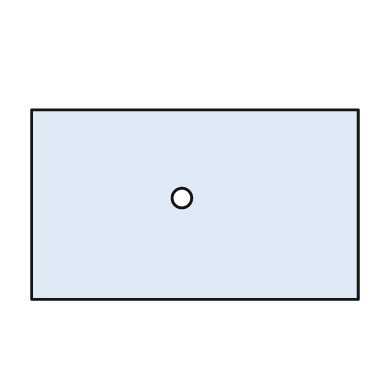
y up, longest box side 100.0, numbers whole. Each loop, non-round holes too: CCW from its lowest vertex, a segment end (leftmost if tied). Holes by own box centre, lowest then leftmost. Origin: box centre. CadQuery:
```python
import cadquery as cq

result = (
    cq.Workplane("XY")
    .moveTo(-50.0, -29.0)
    .lineTo(50.0, -29.0)
    .lineTo(50.0, 29.0)
    .lineTo(-50.0, 29.0)
    .close()
    .moveTo(-4.0, 2.0)
    .circle(3.0)
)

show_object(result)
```